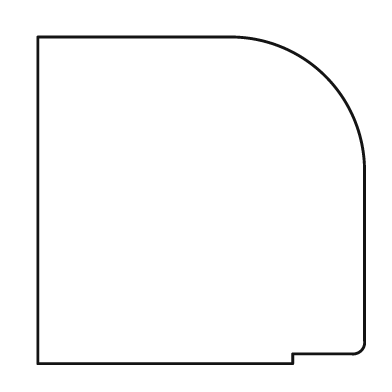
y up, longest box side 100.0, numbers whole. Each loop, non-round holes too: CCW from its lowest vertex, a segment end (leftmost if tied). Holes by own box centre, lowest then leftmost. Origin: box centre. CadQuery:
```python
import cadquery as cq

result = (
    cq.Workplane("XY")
    .moveTo(-50.0, -50.0)
    .lineTo(28.0, -50.0)
    .lineTo(28.0, -47.0)
    .lineTo(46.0, -47.0)
    .threePointArc((49.0, -46.0), (50.0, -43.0))
    .lineTo(50.0, 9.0)
    .threePointArc((38.0, 38.0), (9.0, 50.0))
    .lineTo(-50.0, 50.0)
    .close()
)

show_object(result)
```